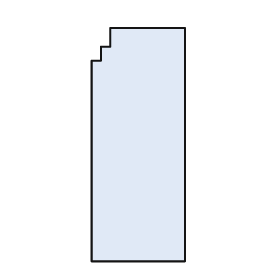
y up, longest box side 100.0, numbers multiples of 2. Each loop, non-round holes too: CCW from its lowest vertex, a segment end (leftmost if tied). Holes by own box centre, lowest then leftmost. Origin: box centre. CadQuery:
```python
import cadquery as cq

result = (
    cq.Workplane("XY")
    .moveTo(-20.0, -50.0)
    .lineTo(20.0, -50.0)
    .lineTo(20.0, 50.0)
    .lineTo(-12.0, 50.0)
    .lineTo(-12.0, 42.0)
    .lineTo(-16.0, 42.0)
    .lineTo(-16.0, 36.0)
    .lineTo(-20.0, 36.0)
    .close()
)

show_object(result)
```